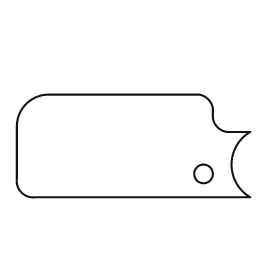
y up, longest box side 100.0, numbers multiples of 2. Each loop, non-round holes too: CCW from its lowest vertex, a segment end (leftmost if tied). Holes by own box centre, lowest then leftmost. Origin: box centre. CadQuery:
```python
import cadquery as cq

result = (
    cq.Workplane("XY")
    .moveTo(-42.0, -22.0)
    .lineTo(50.0, -22.0)
    .threePointArc((42.0, -8.0), (50.0, 6.0))
    .lineTo(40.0, 6.0)
    .threePointArc((36.0, 8.0), (34.0, 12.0))
    .lineTo(34.0, 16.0)
    .threePointArc((32.0, 20.0), (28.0, 22.0))
    .lineTo(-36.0, 22.0)
    .threePointArc((-46.0, 18.0), (-50.0, 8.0))
    .lineTo(-50.0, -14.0)
    .threePointArc((-48.0, -20.0), (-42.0, -22.0))
    .close()
    .moveTo(30.0, -12.0)
    .circle(4.0)
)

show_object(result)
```